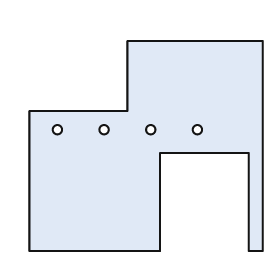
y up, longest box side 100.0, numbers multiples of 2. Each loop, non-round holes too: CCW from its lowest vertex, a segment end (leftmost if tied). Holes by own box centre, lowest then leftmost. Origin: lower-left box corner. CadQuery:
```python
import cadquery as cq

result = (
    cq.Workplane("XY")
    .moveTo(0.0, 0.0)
    .lineTo(56.0, 0.0)
    .lineTo(56.0, 42.0)
    .lineTo(94.0, 42.0)
    .lineTo(94.0, 0.0)
    .lineTo(100.0, 0.0)
    .lineTo(100.0, 90.0)
    .lineTo(42.0, 90.0)
    .lineTo(42.0, 60.0)
    .lineTo(0.0, 60.0)
    .close()
    .moveTo(12.0, 52.0)
    .circle(2.0)
    .moveTo(32.0, 52.0)
    .circle(2.0)
    .moveTo(52.0, 52.0)
    .circle(2.0)
    .moveTo(72.0, 52.0)
    .circle(2.0)
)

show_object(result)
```